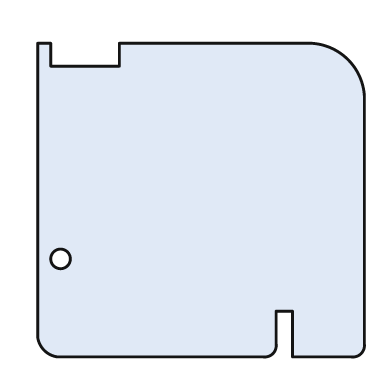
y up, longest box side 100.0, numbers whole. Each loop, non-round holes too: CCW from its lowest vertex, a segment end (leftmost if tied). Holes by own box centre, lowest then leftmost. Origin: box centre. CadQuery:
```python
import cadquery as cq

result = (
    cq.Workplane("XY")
    .moveTo(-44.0, -48.0)
    .lineTo(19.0, -48.0)
    .threePointArc((22.0, -47.0), (23.0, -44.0))
    .lineTo(23.0, -34.0)
    .lineTo(28.0, -34.0)
    .lineTo(28.0, -48.0)
    .lineTo(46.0, -48.0)
    .threePointArc((49.0, -47.0), (50.0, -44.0))
    .lineTo(50.0, 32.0)
    .threePointArc((45.0, 43.0), (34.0, 48.0))
    .lineTo(-25.0, 48.0)
    .lineTo(-25.0, 41.0)
    .lineTo(-46.0, 41.0)
    .lineTo(-46.0, 48.0)
    .lineTo(-50.0, 48.0)
    .lineTo(-50.0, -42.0)
    .threePointArc((-48.0, -46.0), (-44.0, -48.0))
    .close()
    .moveTo(-43.0, -18.0)
    .circle(3.0)
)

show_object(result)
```